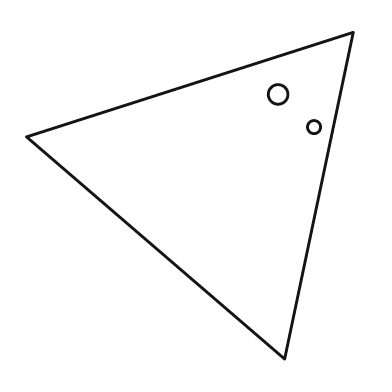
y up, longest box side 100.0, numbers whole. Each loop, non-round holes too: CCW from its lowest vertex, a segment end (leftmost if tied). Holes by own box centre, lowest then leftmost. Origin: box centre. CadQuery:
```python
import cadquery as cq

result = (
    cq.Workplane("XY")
    .moveTo(29.0, -50.0)
    .lineTo(50.0, 50.0)
    .lineTo(-50.0, 18.0)
    .close()
    .moveTo(38.0, 21.0)
    .circle(2.0)
    .moveTo(27.0, 31.0)
    .circle(3.0)
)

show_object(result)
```